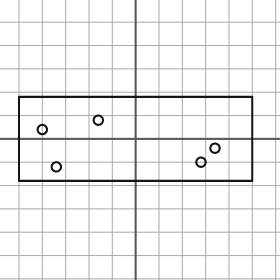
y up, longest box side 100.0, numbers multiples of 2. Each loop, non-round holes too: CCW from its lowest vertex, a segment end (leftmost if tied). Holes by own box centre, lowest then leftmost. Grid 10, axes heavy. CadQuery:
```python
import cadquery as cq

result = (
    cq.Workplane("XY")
    .moveTo(-50.0, -18.0)
    .lineTo(50.0, -18.0)
    .lineTo(50.0, 18.0)
    .lineTo(-50.0, 18.0)
    .close()
    .moveTo(-34.0, -12.0)
    .circle(2.0)
    .moveTo(28.0, -10.0)
    .circle(2.0)
    .moveTo(34.0, -4.0)
    .circle(2.0)
    .moveTo(-40.0, 4.0)
    .circle(2.0)
    .moveTo(-16.0, 8.0)
    .circle(2.0)
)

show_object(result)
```